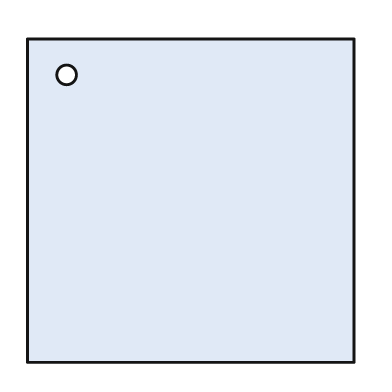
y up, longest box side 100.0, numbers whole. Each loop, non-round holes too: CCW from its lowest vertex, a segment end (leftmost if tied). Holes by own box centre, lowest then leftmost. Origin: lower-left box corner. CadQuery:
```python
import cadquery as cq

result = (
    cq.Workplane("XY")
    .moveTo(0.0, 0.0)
    .lineTo(100.0, 0.0)
    .lineTo(100.0, 99.0)
    .lineTo(0.0, 99.0)
    .close()
    .moveTo(12.0, 88.0)
    .circle(3.0)
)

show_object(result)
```